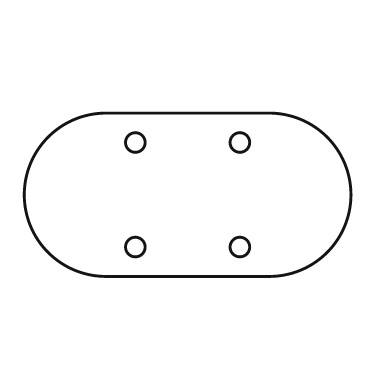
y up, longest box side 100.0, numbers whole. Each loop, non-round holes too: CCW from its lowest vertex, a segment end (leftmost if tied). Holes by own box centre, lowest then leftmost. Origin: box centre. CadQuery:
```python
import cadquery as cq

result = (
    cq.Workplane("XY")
    .moveTo(-25.0, -25.0)
    .lineTo(25.0, -25.0)
    .threePointArc((50.0, 0.0), (25.0, 25.0))
    .lineTo(-25.0, 25.0)
    .threePointArc((-50.0, 0.0), (-25.0, -25.0))
    .close()
    .moveTo(-16.0, -16.0)
    .circle(3.0)
    .moveTo(16.0, -16.0)
    .circle(3.0)
    .moveTo(-16.0, 16.0)
    .circle(3.0)
    .moveTo(16.0, 16.0)
    .circle(3.0)
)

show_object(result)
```